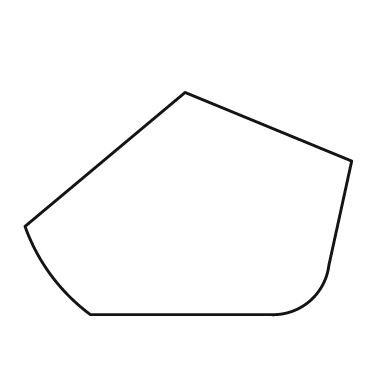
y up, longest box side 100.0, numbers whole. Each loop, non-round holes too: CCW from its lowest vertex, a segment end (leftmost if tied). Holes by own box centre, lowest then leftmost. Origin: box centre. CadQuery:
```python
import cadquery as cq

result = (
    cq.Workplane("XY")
    .moveTo(-30.0, -34.0)
    .lineTo(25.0, -34.0)
    .threePointArc((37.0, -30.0), (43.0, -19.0))
    .lineTo(50.0, 13.0)
    .lineTo(-1.0, 34.0)
    .lineTo(-50.0, -7.0)
    .threePointArc((-42.0, -22.0), (-30.0, -34.0))
    .close()
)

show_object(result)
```